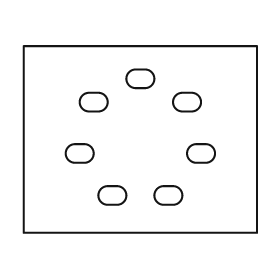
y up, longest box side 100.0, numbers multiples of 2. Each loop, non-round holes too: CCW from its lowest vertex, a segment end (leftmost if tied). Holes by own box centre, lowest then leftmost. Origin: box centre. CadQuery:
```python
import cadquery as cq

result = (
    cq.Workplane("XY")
    .moveTo(-50.0, -40.0)
    .lineTo(50.0, -40.0)
    .lineTo(50.0, 40.0)
    .lineTo(-50.0, 40.0)
    .close()
    .moveTo(-14.0, -28.0)
    .lineTo(-10.0, -28.0)
    .threePointArc((-6.0, -24.0), (-10.0, -20.0))
    .lineTo(-14.0, -20.0)
    .threePointArc((-18.0, -24.0), (-14.0, -28.0))
    .close()
    .moveTo(10.0, -28.0)
    .lineTo(14.0, -28.0)
    .threePointArc((18.0, -24.0), (14.0, -20.0))
    .lineTo(10.0, -20.0)
    .threePointArc((6.0, -24.0), (10.0, -28.0))
    .close()
    .moveTo(-28.0, -10.0)
    .lineTo(-24.0, -10.0)
    .threePointArc((-20.0, -6.0), (-24.0, -2.0))
    .lineTo(-28.0, -2.0)
    .threePointArc((-32.0, -6.0), (-28.0, -10.0))
    .close()
    .moveTo(24.0, -10.0)
    .lineTo(28.0, -10.0)
    .threePointArc((32.0, -6.0), (28.0, -2.0))
    .lineTo(24.0, -2.0)
    .threePointArc((20.0, -6.0), (24.0, -10.0))
    .close()
    .moveTo(-22.0, 12.0)
    .lineTo(-18.0, 12.0)
    .threePointArc((-14.0, 16.0), (-18.0, 20.0))
    .lineTo(-22.0, 20.0)
    .threePointArc((-26.0, 16.0), (-22.0, 12.0))
    .close()
    .moveTo(18.0, 12.0)
    .lineTo(22.0, 12.0)
    .threePointArc((26.0, 16.0), (22.0, 20.0))
    .lineTo(18.0, 20.0)
    .threePointArc((14.0, 16.0), (18.0, 12.0))
    .close()
    .moveTo(-2.0, 22.0)
    .lineTo(2.0, 22.0)
    .threePointArc((6.0, 26.0), (2.0, 30.0))
    .lineTo(-2.0, 30.0)
    .threePointArc((-6.0, 26.0), (-2.0, 22.0))
    .close()
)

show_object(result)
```